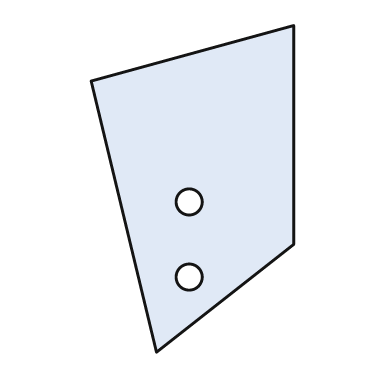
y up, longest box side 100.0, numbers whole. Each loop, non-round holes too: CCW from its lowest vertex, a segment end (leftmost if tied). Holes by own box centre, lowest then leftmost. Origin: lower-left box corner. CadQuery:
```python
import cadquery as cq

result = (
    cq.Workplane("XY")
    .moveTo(20.0, 0.0)
    .lineTo(62.0, 33.0)
    .lineTo(62.0, 100.0)
    .lineTo(0.0, 83.0)
    .close()
    .moveTo(30.0, 23.0)
    .circle(4.0)
    .moveTo(30.0, 46.0)
    .circle(4.0)
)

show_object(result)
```